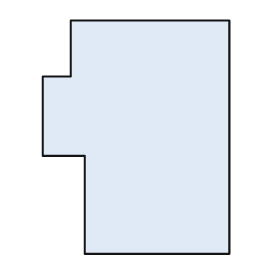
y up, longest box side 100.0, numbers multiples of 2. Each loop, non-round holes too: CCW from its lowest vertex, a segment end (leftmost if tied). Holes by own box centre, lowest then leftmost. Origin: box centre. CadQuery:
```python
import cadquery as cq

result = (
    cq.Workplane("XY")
    .moveTo(-22.0, -50.0)
    .lineTo(40.0, -50.0)
    .lineTo(40.0, 50.0)
    .lineTo(-28.0, 50.0)
    .lineTo(-28.0, 26.0)
    .lineTo(-40.0, 26.0)
    .lineTo(-40.0, -8.0)
    .lineTo(-22.0, -8.0)
    .close()
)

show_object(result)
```